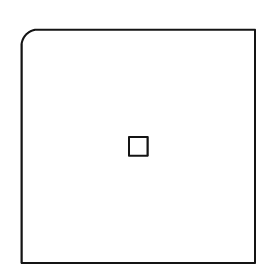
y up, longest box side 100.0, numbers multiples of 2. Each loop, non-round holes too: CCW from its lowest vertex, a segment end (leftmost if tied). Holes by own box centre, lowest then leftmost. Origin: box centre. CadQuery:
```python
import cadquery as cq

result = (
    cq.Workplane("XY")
    .moveTo(-50.0, -50.0)
    .lineTo(50.0, -50.0)
    .lineTo(50.0, 50.0)
    .lineTo(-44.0, 50.0)
    .threePointArc((-48.0, 48.0), (-50.0, 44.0))
    .close()
    .moveTo(-4.0, -4.0)
    .lineTo(4.0, -4.0)
    .lineTo(4.0, 4.0)
    .lineTo(-4.0, 4.0)
    .close()
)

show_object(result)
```